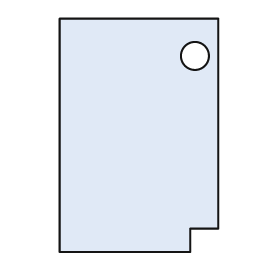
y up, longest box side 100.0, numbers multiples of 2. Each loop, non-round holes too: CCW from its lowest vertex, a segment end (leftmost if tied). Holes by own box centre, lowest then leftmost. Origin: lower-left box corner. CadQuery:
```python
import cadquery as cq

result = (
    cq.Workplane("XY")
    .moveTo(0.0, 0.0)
    .lineTo(56.0, 0.0)
    .lineTo(56.0, 10.0)
    .lineTo(68.0, 10.0)
    .lineTo(68.0, 100.0)
    .lineTo(0.0, 100.0)
    .close()
    .moveTo(58.0, 84.0)
    .circle(6.0)
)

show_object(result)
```